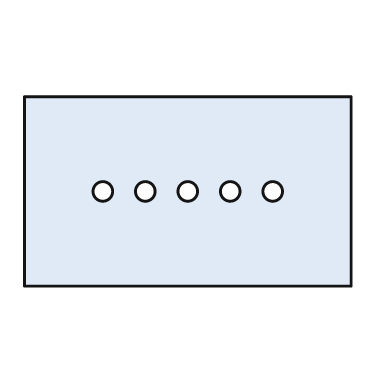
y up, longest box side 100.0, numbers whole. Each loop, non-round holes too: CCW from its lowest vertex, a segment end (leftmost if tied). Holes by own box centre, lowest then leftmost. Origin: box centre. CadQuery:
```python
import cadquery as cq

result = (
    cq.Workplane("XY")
    .moveTo(-50.0, -29.0)
    .lineTo(50.0, -29.0)
    .lineTo(50.0, 29.0)
    .lineTo(-50.0, 29.0)
    .close()
    .moveTo(-26.0, 0.0)
    .circle(3.0)
    .moveTo(-13.0, 0.0)
    .circle(3.0)
    .moveTo(0.0, 0.0)
    .circle(3.0)
    .moveTo(13.0, 0.0)
    .circle(3.0)
    .moveTo(26.0, 0.0)
    .circle(3.0)
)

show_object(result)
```